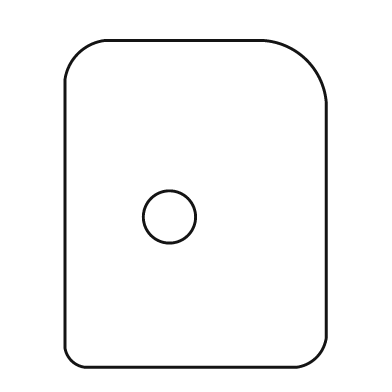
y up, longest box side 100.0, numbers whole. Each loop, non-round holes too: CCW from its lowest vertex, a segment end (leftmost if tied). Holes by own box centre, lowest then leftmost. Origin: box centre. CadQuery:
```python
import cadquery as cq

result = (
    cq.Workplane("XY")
    .moveTo(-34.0, -50.0)
    .lineTo(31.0, -50.0)
    .threePointArc((37.0, -47.0), (40.0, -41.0))
    .lineTo(40.0, 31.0)
    .threePointArc((34.0, 44.0), (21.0, 50.0))
    .lineTo(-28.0, 50.0)
    .threePointArc((-36.0, 46.0), (-40.0, 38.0))
    .lineTo(-40.0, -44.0)
    .threePointArc((-38.0, -48.0), (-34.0, -50.0))
    .close()
    .moveTo(-8.0, -4.0)
    .circle(8.0)
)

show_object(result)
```